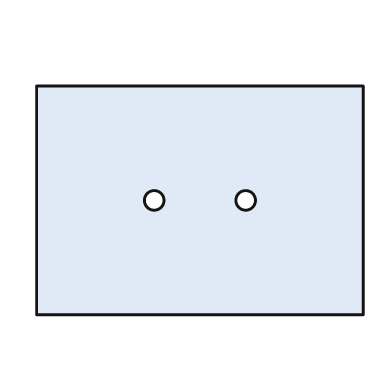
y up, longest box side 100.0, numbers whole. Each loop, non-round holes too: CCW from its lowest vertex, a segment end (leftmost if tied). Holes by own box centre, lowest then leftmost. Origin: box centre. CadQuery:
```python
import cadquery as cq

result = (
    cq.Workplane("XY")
    .moveTo(-50.0, -35.0)
    .lineTo(50.0, -35.0)
    .lineTo(50.0, 35.0)
    .lineTo(-50.0, 35.0)
    .close()
    .moveTo(-14.0, 0.0)
    .circle(3.0)
    .moveTo(14.0, 0.0)
    .circle(3.0)
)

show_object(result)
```